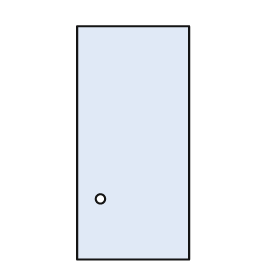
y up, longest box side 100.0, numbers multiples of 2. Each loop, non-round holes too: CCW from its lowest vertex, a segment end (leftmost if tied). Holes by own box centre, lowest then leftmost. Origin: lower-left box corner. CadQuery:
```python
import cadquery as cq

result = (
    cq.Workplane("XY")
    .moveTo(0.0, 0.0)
    .lineTo(48.0, 0.0)
    .lineTo(48.0, 100.0)
    .lineTo(0.0, 100.0)
    .close()
    .moveTo(10.0, 26.0)
    .circle(2.0)
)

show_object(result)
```